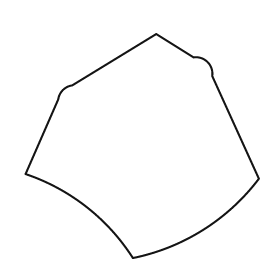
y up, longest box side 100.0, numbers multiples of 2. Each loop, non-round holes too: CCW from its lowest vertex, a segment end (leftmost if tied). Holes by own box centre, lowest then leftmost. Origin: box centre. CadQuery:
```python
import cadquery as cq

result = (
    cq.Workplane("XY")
    .moveTo(-4.0, -48.0)
    .threePointArc((26.0, -36.0), (50.0, -14.0))
    .lineTo(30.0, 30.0)
    .threePointArc((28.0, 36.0), (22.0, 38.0))
    .lineTo(6.0, 48.0)
    .lineTo(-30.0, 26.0)
    .threePointArc((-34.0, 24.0), (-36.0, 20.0))
    .lineTo(-50.0, -12.0)
    .threePointArc((-24.0, -26.0), (-4.0, -48.0))
    .close()
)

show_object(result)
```